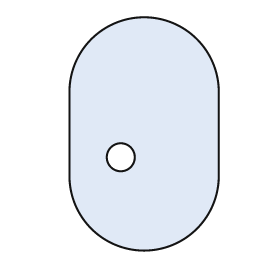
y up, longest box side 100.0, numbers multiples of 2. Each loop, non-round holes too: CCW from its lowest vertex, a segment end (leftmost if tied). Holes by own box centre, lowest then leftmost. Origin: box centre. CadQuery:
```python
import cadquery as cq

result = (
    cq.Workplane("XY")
    .moveTo(-32.0, -18.0)
    .threePointArc((0.0, -50.0), (32.0, -18.0))
    .lineTo(32.0, 18.0)
    .threePointArc((0.0, 50.0), (-32.0, 18.0))
    .close()
    .moveTo(-10.0, -10.0)
    .circle(6.0)
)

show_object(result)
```